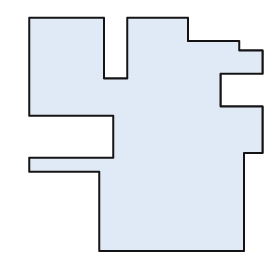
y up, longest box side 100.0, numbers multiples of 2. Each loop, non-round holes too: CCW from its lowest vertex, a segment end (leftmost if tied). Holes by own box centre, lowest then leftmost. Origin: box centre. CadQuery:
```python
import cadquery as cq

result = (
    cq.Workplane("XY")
    .moveTo(-20.0, -50.0)
    .lineTo(42.0, -50.0)
    .lineTo(42.0, -8.0)
    .lineTo(50.0, -8.0)
    .lineTo(50.0, 12.0)
    .lineTo(32.0, 12.0)
    .lineTo(32.0, 26.0)
    .lineTo(50.0, 26.0)
    .lineTo(50.0, 36.0)
    .lineTo(40.0, 36.0)
    .lineTo(40.0, 40.0)
    .lineTo(18.0, 40.0)
    .lineTo(18.0, 50.0)
    .lineTo(-8.0, 50.0)
    .lineTo(-8.0, 24.0)
    .lineTo(-18.0, 24.0)
    .lineTo(-18.0, 50.0)
    .lineTo(-50.0, 50.0)
    .lineTo(-50.0, 8.0)
    .lineTo(-14.0, 8.0)
    .lineTo(-14.0, -10.0)
    .lineTo(-50.0, -10.0)
    .lineTo(-50.0, -16.0)
    .lineTo(-20.0, -16.0)
    .close()
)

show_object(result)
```